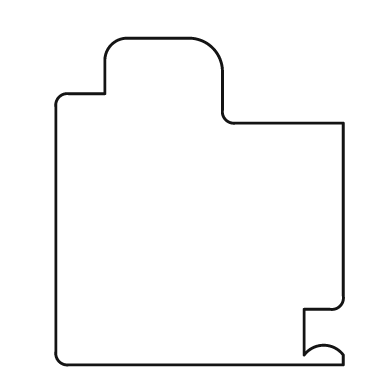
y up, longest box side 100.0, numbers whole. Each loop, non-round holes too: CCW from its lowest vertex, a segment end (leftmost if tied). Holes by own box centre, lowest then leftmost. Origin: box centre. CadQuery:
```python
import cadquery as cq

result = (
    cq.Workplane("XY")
    .moveTo(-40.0, -50.0)
    .lineTo(44.0, -50.0)
    .lineTo(44.0, -47.0)
    .threePointArc((38.0, -44.0), (32.0, -47.0))
    .lineTo(32.0, -33.0)
    .lineTo(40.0, -33.0)
    .threePointArc((43.0, -32.0), (44.0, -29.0))
    .lineTo(44.0, 24.0)
    .lineTo(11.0, 24.0)
    .threePointArc((8.0, 25.0), (7.0, 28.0))
    .lineTo(7.0, 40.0)
    .threePointArc((4.0, 47.0), (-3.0, 50.0))
    .lineTo(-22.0, 50.0)
    .threePointArc((-27.0, 48.0), (-29.0, 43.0))
    .lineTo(-29.0, 33.0)
    .lineTo(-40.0, 33.0)
    .threePointArc((-43.0, 32.0), (-44.0, 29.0))
    .lineTo(-44.0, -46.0)
    .threePointArc((-43.0, -49.0), (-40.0, -50.0))
    .close()
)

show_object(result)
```